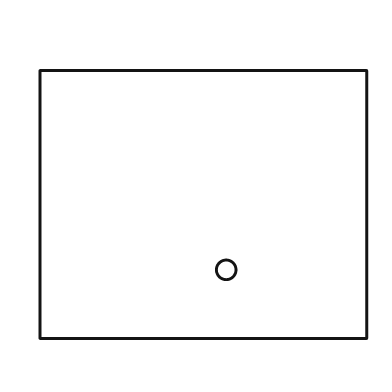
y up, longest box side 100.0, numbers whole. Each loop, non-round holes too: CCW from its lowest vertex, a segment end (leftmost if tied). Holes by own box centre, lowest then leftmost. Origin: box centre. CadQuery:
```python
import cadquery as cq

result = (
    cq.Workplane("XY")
    .moveTo(-50.0, -41.0)
    .lineTo(50.0, -41.0)
    .lineTo(50.0, 41.0)
    .lineTo(-50.0, 41.0)
    .close()
    .moveTo(7.0, -20.0)
    .circle(3.0)
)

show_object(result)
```